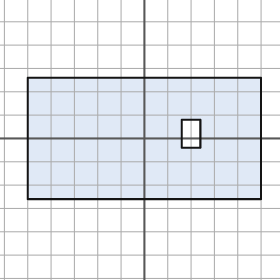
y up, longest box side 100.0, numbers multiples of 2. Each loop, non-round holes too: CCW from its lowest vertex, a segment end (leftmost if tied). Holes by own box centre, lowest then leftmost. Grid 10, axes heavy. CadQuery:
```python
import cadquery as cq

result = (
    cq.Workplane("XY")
    .moveTo(-50.0, -26.0)
    .lineTo(50.0, -26.0)
    .lineTo(50.0, 26.0)
    .lineTo(-50.0, 26.0)
    .close()
    .moveTo(16.0, -4.0)
    .lineTo(24.0, -4.0)
    .lineTo(24.0, 8.0)
    .lineTo(16.0, 8.0)
    .close()
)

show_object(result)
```